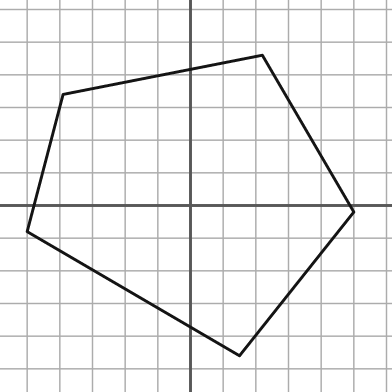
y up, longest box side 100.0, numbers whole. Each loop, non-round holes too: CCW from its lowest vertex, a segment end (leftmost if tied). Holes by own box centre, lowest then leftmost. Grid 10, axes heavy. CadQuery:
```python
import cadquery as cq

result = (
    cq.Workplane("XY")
    .moveTo(15.0, -46.0)
    .lineTo(50.0, -2.0)
    .lineTo(22.0, 46.0)
    .lineTo(-39.0, 34.0)
    .lineTo(-50.0, -8.0)
    .close()
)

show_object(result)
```